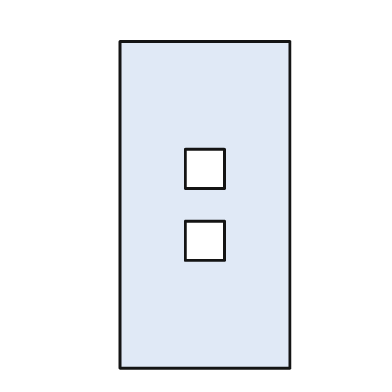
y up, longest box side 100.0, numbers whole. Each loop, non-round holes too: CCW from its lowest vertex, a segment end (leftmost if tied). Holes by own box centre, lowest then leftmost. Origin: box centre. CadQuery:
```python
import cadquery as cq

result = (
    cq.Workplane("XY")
    .moveTo(-26.0, -50.0)
    .lineTo(26.0, -50.0)
    .lineTo(26.0, 50.0)
    .lineTo(-26.0, 50.0)
    .close()
    .moveTo(-6.0, -17.0)
    .lineTo(6.0, -17.0)
    .lineTo(6.0, -5.0)
    .lineTo(-6.0, -5.0)
    .close()
    .moveTo(-6.0, 5.0)
    .lineTo(6.0, 5.0)
    .lineTo(6.0, 17.0)
    .lineTo(-6.0, 17.0)
    .close()
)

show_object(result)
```